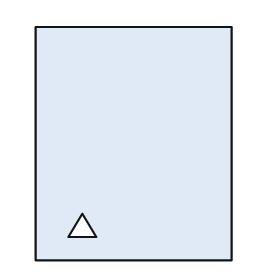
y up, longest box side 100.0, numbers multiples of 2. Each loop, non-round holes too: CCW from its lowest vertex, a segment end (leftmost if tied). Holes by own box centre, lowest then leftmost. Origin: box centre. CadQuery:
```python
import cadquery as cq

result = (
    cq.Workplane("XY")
    .moveTo(-42.0, -50.0)
    .lineTo(42.0, -50.0)
    .lineTo(42.0, 50.0)
    .lineTo(-42.0, 50.0)
    .close()
    .moveTo(-28.0, -40.0)
    .lineTo(-16.0, -40.0)
    .lineTo(-22.0, -30.0)
    .close()
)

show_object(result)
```